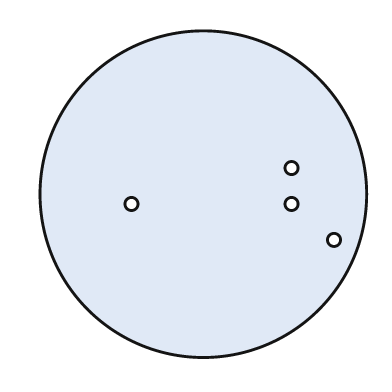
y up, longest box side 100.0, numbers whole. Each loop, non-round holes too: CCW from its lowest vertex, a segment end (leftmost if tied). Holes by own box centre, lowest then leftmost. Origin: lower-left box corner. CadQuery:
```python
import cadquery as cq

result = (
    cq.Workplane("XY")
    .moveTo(50.0, 50.0)
    .circle(50.0)
    .moveTo(90.0, 36.0)
    .circle(2.0)
    .moveTo(28.0, 47.0)
    .circle(2.0)
    .moveTo(77.0, 47.0)
    .circle(2.0)
    .moveTo(77.0, 58.0)
    .circle(2.0)
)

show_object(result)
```